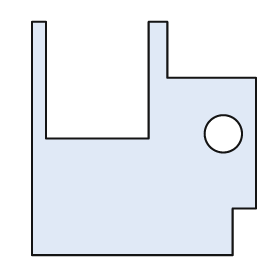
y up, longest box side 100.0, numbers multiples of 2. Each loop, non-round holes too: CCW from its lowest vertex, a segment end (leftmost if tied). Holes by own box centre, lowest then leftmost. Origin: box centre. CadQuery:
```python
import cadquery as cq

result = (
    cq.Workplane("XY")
    .moveTo(-48.0, -50.0)
    .lineTo(38.0, -50.0)
    .lineTo(38.0, -30.0)
    .lineTo(48.0, -30.0)
    .lineTo(48.0, 26.0)
    .lineTo(10.0, 26.0)
    .lineTo(10.0, 50.0)
    .lineTo(2.0, 50.0)
    .lineTo(2.0, 0.0)
    .lineTo(-42.0, 0.0)
    .lineTo(-42.0, 50.0)
    .lineTo(-48.0, 50.0)
    .close()
    .moveTo(34.0, 2.0)
    .circle(8.0)
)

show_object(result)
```